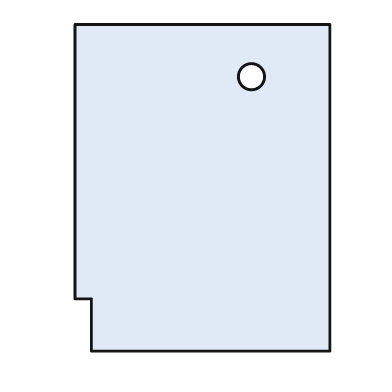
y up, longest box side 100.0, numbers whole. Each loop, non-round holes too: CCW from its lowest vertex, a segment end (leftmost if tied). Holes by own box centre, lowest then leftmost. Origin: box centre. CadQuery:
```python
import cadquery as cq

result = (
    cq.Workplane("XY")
    .moveTo(-34.0, -50.0)
    .lineTo(39.0, -50.0)
    .lineTo(39.0, 50.0)
    .lineTo(-39.0, 50.0)
    .lineTo(-39.0, -34.0)
    .lineTo(-34.0, -34.0)
    .close()
    .moveTo(15.0, 34.0)
    .circle(4.0)
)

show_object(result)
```